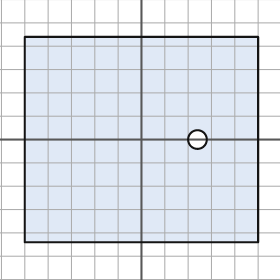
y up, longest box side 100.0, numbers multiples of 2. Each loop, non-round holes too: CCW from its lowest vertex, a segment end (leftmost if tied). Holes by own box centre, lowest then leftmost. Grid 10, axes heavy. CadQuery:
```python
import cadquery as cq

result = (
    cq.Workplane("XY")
    .moveTo(-50.0, -44.0)
    .lineTo(50.0, -44.0)
    .lineTo(50.0, 44.0)
    .lineTo(-50.0, 44.0)
    .close()
    .moveTo(24.0, 0.0)
    .circle(4.0)
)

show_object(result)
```